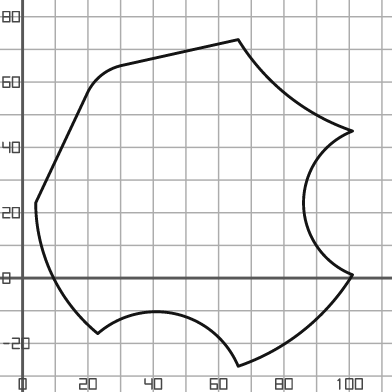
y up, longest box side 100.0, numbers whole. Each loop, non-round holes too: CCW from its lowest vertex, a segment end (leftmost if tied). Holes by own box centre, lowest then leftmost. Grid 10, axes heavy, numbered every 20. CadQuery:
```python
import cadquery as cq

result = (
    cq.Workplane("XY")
    .moveTo(66.0, -27.0)
    .threePointArc((86.0, -16.0), (101.0, 1.0))
    .threePointArc((86.0, 23.0), (101.0, 45.0))
    .threePointArc((81.0, 56.0), (66.0, 73.0))
    .lineTo(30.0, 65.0)
    .threePointArc((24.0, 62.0), (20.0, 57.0))
    .lineTo(4.0, 23.0)
    .threePointArc((9.0, 1.0), (23.0, -17.0))
    .threePointArc((47.0, -11.0), (66.0, -27.0))
    .close()
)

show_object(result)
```